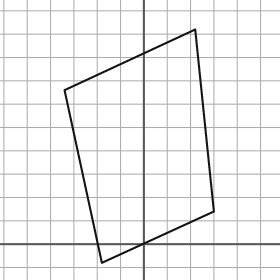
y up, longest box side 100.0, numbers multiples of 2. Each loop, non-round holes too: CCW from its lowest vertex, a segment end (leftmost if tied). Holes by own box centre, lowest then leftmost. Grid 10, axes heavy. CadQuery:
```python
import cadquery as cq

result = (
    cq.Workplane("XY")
    .moveTo(-18.0, -8.0)
    .lineTo(30.0, 14.0)
    .lineTo(22.0, 92.0)
    .lineTo(-34.0, 66.0)
    .close()
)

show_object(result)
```